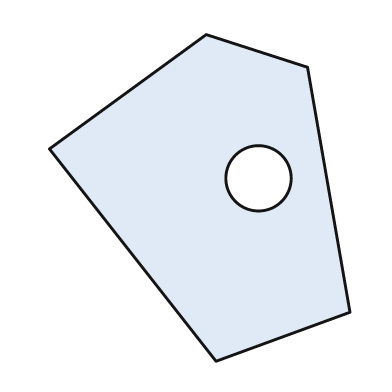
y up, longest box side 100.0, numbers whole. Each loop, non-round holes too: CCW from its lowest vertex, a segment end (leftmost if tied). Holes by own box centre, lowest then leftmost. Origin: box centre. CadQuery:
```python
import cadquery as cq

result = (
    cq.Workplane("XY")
    .moveTo(5.0, -50.0)
    .lineTo(46.0, -35.0)
    .lineTo(33.0, 40.0)
    .lineTo(2.0, 50.0)
    .lineTo(-46.0, 15.0)
    .close()
    .moveTo(18.0, 6.0)
    .circle(10.0)
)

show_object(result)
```